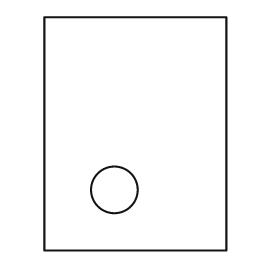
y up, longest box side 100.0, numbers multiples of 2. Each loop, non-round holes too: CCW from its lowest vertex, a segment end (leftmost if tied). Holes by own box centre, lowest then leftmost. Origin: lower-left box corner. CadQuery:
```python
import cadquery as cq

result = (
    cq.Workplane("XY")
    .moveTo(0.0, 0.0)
    .lineTo(78.0, 0.0)
    .lineTo(78.0, 100.0)
    .lineTo(0.0, 100.0)
    .close()
    .moveTo(30.0, 26.0)
    .circle(10.0)
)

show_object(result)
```